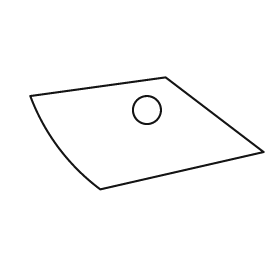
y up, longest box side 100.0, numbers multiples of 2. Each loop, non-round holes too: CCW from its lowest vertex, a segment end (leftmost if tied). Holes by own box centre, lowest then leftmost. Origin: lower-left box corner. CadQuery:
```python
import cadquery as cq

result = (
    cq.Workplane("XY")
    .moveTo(30.0, 0.0)
    .lineTo(100.0, 16.0)
    .lineTo(58.0, 48.0)
    .lineTo(0.0, 40.0)
    .threePointArc((12.0, 18.0), (30.0, 0.0))
    .close()
    .moveTo(50.0, 34.0)
    .circle(6.0)
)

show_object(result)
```